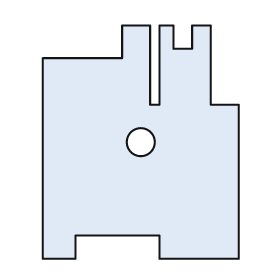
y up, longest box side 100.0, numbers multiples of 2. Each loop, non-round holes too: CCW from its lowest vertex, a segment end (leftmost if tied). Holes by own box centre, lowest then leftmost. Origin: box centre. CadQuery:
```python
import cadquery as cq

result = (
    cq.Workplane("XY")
    .moveTo(-42.0, -50.0)
    .lineTo(-28.0, -50.0)
    .lineTo(-28.0, -40.0)
    .lineTo(8.0, -40.0)
    .lineTo(8.0, -50.0)
    .lineTo(42.0, -50.0)
    .lineTo(42.0, 16.0)
    .lineTo(30.0, 16.0)
    .lineTo(30.0, 50.0)
    .lineTo(22.0, 50.0)
    .lineTo(22.0, 40.0)
    .lineTo(14.0, 40.0)
    .lineTo(14.0, 50.0)
    .lineTo(8.0, 50.0)
    .lineTo(8.0, 16.0)
    .lineTo(4.0, 16.0)
    .lineTo(4.0, 50.0)
    .lineTo(-8.0, 50.0)
    .lineTo(-8.0, 36.0)
    .lineTo(-42.0, 36.0)
    .close()
    .moveTo(0.0, 0.0)
    .circle(6.0)
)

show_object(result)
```